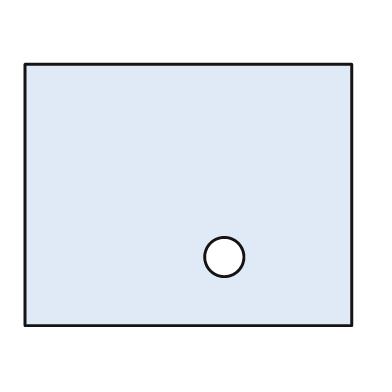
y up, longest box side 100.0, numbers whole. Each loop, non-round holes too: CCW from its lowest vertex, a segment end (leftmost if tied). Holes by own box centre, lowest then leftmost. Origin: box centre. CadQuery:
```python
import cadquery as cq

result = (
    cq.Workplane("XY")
    .moveTo(-50.0, -40.0)
    .lineTo(50.0, -40.0)
    .lineTo(50.0, 40.0)
    .lineTo(-50.0, 40.0)
    .close()
    .moveTo(11.0, -19.0)
    .circle(6.0)
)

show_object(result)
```